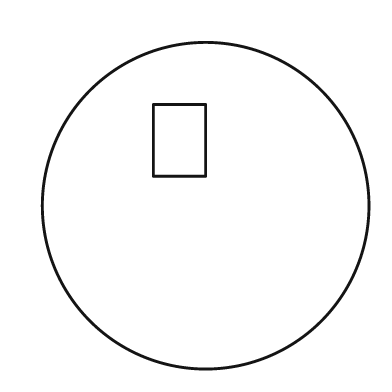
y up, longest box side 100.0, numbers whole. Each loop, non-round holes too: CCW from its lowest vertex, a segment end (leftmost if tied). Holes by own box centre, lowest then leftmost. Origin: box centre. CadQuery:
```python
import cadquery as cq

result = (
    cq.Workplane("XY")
    .moveTo(0.0, 0.0)
    .circle(50.0)
    .moveTo(-16.0, 9.0)
    .lineTo(0.0, 9.0)
    .lineTo(0.0, 31.0)
    .lineTo(-16.0, 31.0)
    .close()
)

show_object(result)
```